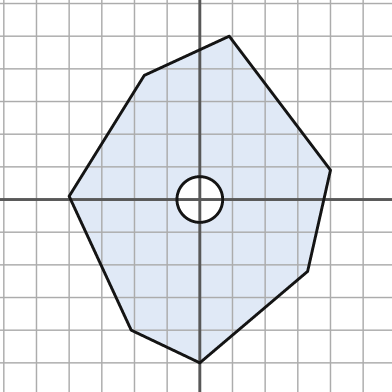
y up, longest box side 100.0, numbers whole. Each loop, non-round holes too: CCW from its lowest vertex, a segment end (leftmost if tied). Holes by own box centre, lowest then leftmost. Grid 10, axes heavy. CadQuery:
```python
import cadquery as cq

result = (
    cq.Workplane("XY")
    .moveTo(0.0, -50.0)
    .lineTo(33.0, -22.0)
    .lineTo(40.0, 9.0)
    .lineTo(9.0, 50.0)
    .lineTo(-17.0, 38.0)
    .lineTo(-40.0, 1.0)
    .lineTo(-21.0, -40.0)
    .close()
    .moveTo(0.0, 0.0)
    .circle(7.0)
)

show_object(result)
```